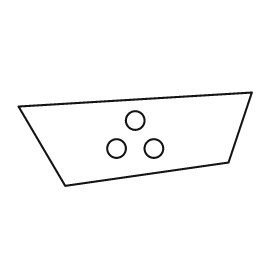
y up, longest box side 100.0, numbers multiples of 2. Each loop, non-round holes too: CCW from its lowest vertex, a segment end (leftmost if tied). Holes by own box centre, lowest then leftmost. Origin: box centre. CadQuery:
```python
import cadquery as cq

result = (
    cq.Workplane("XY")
    .moveTo(-30.0, -20.0)
    .lineTo(40.0, -10.0)
    .lineTo(50.0, 20.0)
    .lineTo(-50.0, 14.0)
    .close()
    .moveTo(-8.0, -4.0)
    .circle(4.0)
    .moveTo(8.0, -4.0)
    .circle(4.0)
    .moveTo(0.0, 8.0)
    .circle(4.0)
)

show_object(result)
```